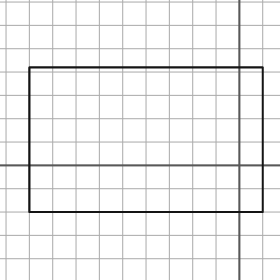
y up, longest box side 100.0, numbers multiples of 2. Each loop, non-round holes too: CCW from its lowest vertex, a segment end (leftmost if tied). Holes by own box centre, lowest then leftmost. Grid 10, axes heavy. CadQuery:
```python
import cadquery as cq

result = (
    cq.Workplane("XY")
    .moveTo(-90.0, -20.0)
    .lineTo(10.0, -20.0)
    .lineTo(10.0, 42.0)
    .lineTo(-90.0, 42.0)
    .close()
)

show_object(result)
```